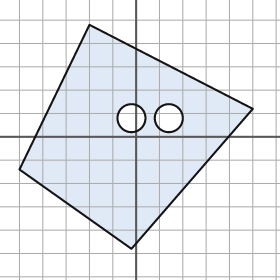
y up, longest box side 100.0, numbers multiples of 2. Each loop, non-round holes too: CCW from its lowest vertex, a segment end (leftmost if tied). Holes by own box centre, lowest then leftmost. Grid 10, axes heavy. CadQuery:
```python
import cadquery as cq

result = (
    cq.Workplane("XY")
    .moveTo(-2.0, -48.0)
    .lineTo(50.0, 12.0)
    .lineTo(-20.0, 48.0)
    .lineTo(-50.0, -14.0)
    .close()
    .moveTo(-2.0, 8.0)
    .circle(6.0)
    .moveTo(14.0, 8.0)
    .circle(6.0)
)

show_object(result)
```